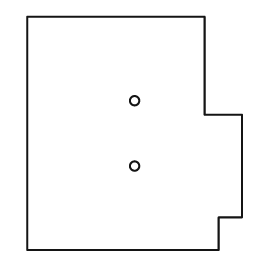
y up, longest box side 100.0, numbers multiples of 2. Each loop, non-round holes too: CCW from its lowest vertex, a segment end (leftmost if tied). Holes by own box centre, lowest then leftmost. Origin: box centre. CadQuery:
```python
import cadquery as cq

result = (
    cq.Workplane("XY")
    .moveTo(-46.0, -50.0)
    .lineTo(36.0, -50.0)
    .lineTo(36.0, -36.0)
    .lineTo(46.0, -36.0)
    .lineTo(46.0, 8.0)
    .lineTo(30.0, 8.0)
    .lineTo(30.0, 50.0)
    .lineTo(-46.0, 50.0)
    .close()
    .moveTo(0.0, -14.0)
    .circle(2.0)
    .moveTo(0.0, 14.0)
    .circle(2.0)
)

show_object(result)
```